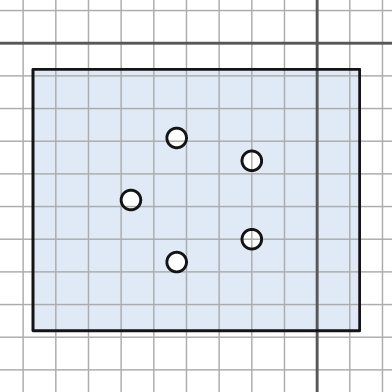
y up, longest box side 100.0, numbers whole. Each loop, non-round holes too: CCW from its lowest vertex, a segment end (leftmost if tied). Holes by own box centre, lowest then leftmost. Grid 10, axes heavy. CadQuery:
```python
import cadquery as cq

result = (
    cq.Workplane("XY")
    .moveTo(-87.0, -88.0)
    .lineTo(13.0, -88.0)
    .lineTo(13.0, -8.0)
    .lineTo(-87.0, -8.0)
    .close()
    .moveTo(-43.0, -67.0)
    .circle(3.0)
    .moveTo(-20.0, -60.0)
    .circle(3.0)
    .moveTo(-57.0, -48.0)
    .circle(3.0)
    .moveTo(-20.0, -36.0)
    .circle(3.0)
    .moveTo(-43.0, -29.0)
    .circle(3.0)
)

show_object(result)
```